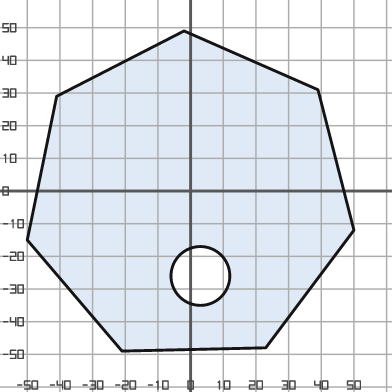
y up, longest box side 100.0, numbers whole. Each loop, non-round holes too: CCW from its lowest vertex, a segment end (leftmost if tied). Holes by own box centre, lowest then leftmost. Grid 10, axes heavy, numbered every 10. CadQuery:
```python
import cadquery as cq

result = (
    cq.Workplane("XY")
    .moveTo(-21.0, -49.0)
    .lineTo(23.0, -48.0)
    .lineTo(50.0, -12.0)
    .lineTo(39.0, 31.0)
    .lineTo(-2.0, 49.0)
    .lineTo(-41.0, 29.0)
    .lineTo(-50.0, -15.0)
    .close()
    .moveTo(3.0, -26.0)
    .circle(9.0)
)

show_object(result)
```